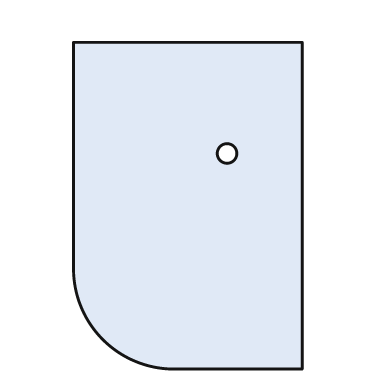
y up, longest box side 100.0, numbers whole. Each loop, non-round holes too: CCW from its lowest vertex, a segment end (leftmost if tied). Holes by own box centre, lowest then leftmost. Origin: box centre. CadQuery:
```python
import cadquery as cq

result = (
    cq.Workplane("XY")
    .moveTo(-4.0, -50.0)
    .lineTo(35.0, -50.0)
    .lineTo(35.0, 50.0)
    .lineTo(-35.0, 50.0)
    .lineTo(-35.0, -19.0)
    .threePointArc((-26.0, -41.0), (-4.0, -50.0))
    .close()
    .moveTo(12.0, 16.0)
    .circle(3.0)
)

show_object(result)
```